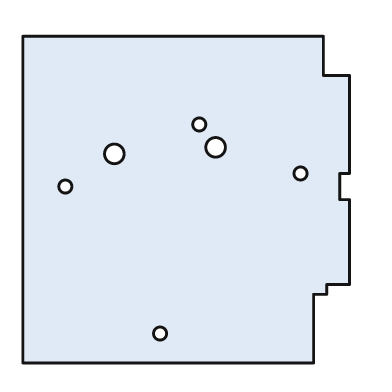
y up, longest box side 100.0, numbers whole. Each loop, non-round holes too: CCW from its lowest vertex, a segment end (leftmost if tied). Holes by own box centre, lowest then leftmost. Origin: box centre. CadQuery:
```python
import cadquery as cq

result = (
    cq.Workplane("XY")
    .moveTo(-50.0, -50.0)
    .lineTo(39.0, -50.0)
    .lineTo(39.0, -29.0)
    .lineTo(43.0, -29.0)
    .lineTo(43.0, -26.0)
    .lineTo(50.0, -26.0)
    .lineTo(50.0, 0.0)
    .lineTo(47.0, 0.0)
    .lineTo(47.0, 8.0)
    .lineTo(50.0, 8.0)
    .lineTo(50.0, 38.0)
    .lineTo(42.0, 38.0)
    .lineTo(42.0, 50.0)
    .lineTo(-50.0, 50.0)
    .close()
    .moveTo(-8.0, -41.0)
    .circle(2.0)
    .moveTo(-37.0, 4.0)
    .circle(2.0)
    .moveTo(35.0, 8.0)
    .circle(2.0)
    .moveTo(-22.0, 14.0)
    .circle(3.0)
    .moveTo(9.0, 16.0)
    .circle(3.0)
    .moveTo(4.0, 23.0)
    .circle(2.0)
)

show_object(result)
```